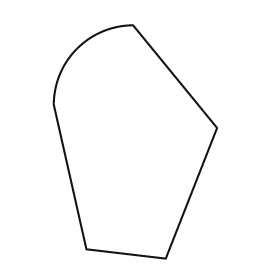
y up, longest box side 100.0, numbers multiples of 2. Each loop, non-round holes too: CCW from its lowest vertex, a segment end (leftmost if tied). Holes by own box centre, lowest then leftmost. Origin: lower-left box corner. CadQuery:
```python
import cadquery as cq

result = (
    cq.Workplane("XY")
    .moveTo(48.0, 0.0)
    .lineTo(70.0, 56.0)
    .lineTo(34.0, 100.0)
    .threePointArc((10.0, 90.0), (0.0, 66.0))
    .lineTo(14.0, 4.0)
    .close()
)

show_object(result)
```